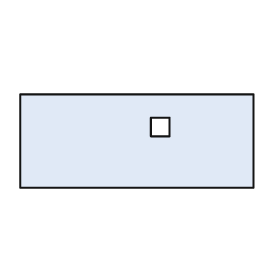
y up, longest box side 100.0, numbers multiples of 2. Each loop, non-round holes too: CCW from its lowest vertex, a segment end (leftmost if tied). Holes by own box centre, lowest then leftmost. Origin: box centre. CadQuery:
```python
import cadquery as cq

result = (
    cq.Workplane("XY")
    .moveTo(-50.0, -20.0)
    .lineTo(50.0, -20.0)
    .lineTo(50.0, 20.0)
    .lineTo(-50.0, 20.0)
    .close()
    .moveTo(6.0, 2.0)
    .lineTo(14.0, 2.0)
    .lineTo(14.0, 10.0)
    .lineTo(6.0, 10.0)
    .close()
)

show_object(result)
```